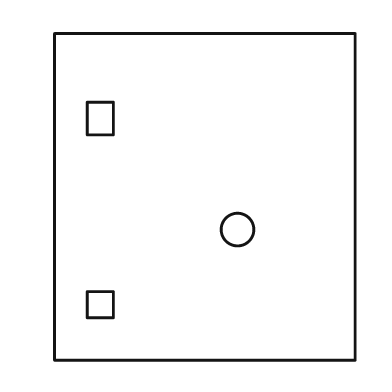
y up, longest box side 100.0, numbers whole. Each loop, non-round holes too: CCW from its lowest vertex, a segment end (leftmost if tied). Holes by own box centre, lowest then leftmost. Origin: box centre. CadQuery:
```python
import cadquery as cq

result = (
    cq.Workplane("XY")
    .moveTo(-46.0, -50.0)
    .lineTo(46.0, -50.0)
    .lineTo(46.0, 50.0)
    .lineTo(-46.0, 50.0)
    .close()
    .moveTo(-36.0, -37.0)
    .lineTo(-28.0, -37.0)
    .lineTo(-28.0, -29.0)
    .lineTo(-36.0, -29.0)
    .close()
    .moveTo(10.0, -10.0)
    .circle(5.0)
    .moveTo(-36.0, 19.0)
    .lineTo(-28.0, 19.0)
    .lineTo(-28.0, 29.0)
    .lineTo(-36.0, 29.0)
    .close()
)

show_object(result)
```